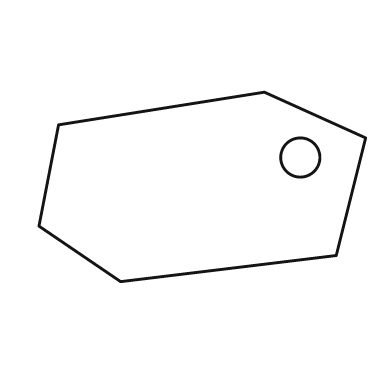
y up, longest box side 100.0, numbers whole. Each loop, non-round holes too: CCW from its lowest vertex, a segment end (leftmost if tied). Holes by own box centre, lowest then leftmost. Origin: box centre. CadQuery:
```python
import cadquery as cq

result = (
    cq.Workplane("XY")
    .moveTo(-25.0, -29.0)
    .lineTo(41.0, -21.0)
    .lineTo(50.0, 15.0)
    .lineTo(19.0, 29.0)
    .lineTo(-44.0, 19.0)
    .lineTo(-50.0, -12.0)
    .close()
    .moveTo(30.0, 9.0)
    .circle(6.0)
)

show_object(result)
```